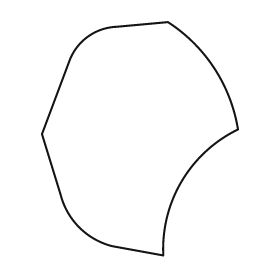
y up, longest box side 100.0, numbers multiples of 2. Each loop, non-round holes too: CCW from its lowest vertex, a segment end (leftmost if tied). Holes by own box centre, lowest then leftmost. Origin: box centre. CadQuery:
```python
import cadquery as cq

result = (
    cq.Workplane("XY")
    .moveTo(10.0, -50.0)
    .threePointArc((18.0, -18.0), (42.0, 4.0))
    .threePointArc((32.0, 30.0), (12.0, 50.0))
    .lineTo(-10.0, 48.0)
    .threePointArc((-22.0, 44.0), (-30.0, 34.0))
    .lineTo(-42.0, 2.0)
    .lineTo(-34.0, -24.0)
    .threePointArc((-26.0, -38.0), (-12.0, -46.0))
    .close()
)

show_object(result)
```